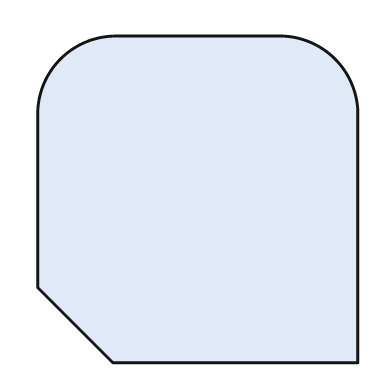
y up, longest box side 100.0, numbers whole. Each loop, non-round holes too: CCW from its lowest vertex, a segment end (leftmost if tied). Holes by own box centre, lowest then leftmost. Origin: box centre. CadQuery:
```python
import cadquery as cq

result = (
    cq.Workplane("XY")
    .moveTo(-26.0, -50.0)
    .lineTo(49.0, -50.0)
    .lineTo(49.0, 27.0)
    .threePointArc((42.0, 43.0), (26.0, 50.0))
    .lineTo(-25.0, 50.0)
    .threePointArc((-42.0, 43.0), (-49.0, 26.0))
    .lineTo(-49.0, -27.0)
    .close()
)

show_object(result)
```